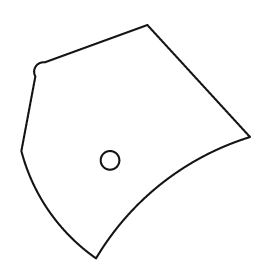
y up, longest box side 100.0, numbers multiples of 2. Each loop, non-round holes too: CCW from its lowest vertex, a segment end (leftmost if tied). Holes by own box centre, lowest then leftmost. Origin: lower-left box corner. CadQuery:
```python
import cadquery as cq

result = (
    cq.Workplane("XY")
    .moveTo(32.0, 0.0)
    .threePointArc((60.0, 32.0), (98.0, 52.0))
    .lineTo(54.0, 100.0)
    .lineTo(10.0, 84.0)
    .threePointArc((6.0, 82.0), (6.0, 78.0))
    .lineTo(0.0, 46.0)
    .threePointArc((12.0, 20.0), (32.0, 0.0))
    .close()
    .moveTo(38.0, 42.0)
    .circle(4.0)
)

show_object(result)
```